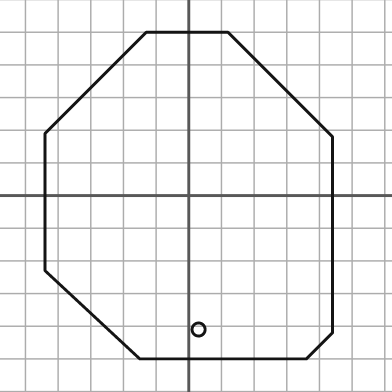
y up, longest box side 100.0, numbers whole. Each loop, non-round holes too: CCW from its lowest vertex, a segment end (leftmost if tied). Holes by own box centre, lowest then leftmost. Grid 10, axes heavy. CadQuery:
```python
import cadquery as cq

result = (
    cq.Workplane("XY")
    .moveTo(-15.0, -50.0)
    .lineTo(36.0, -50.0)
    .lineTo(44.0, -42.0)
    .lineTo(44.0, 18.0)
    .lineTo(12.0, 50.0)
    .lineTo(-13.0, 50.0)
    .lineTo(-44.0, 19.0)
    .lineTo(-44.0, -23.0)
    .close()
    .moveTo(3.0, -41.0)
    .circle(2.0)
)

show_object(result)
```